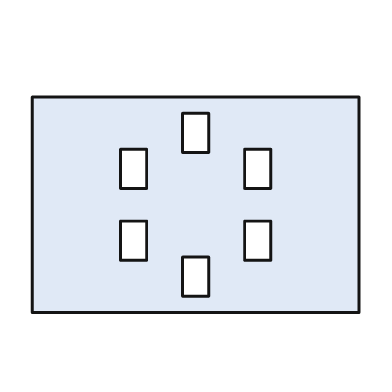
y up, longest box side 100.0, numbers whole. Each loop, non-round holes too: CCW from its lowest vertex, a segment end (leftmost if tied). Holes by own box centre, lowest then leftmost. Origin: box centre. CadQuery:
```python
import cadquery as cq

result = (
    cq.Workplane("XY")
    .moveTo(-50.0, -33.0)
    .lineTo(50.0, -33.0)
    .lineTo(50.0, 33.0)
    .lineTo(-50.0, 33.0)
    .close()
    .moveTo(-4.0, -28.0)
    .lineTo(4.0, -28.0)
    .lineTo(4.0, -16.0)
    .lineTo(-4.0, -16.0)
    .close()
    .moveTo(-23.0, -17.0)
    .lineTo(-15.0, -17.0)
    .lineTo(-15.0, -5.0)
    .lineTo(-23.0, -5.0)
    .close()
    .moveTo(15.0, -17.0)
    .lineTo(23.0, -17.0)
    .lineTo(23.0, -5.0)
    .lineTo(15.0, -5.0)
    .close()
    .moveTo(-23.0, 5.0)
    .lineTo(-15.0, 5.0)
    .lineTo(-15.0, 17.0)
    .lineTo(-23.0, 17.0)
    .close()
    .moveTo(15.0, 5.0)
    .lineTo(23.0, 5.0)
    .lineTo(23.0, 17.0)
    .lineTo(15.0, 17.0)
    .close()
    .moveTo(-4.0, 16.0)
    .lineTo(4.0, 16.0)
    .lineTo(4.0, 28.0)
    .lineTo(-4.0, 28.0)
    .close()
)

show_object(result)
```